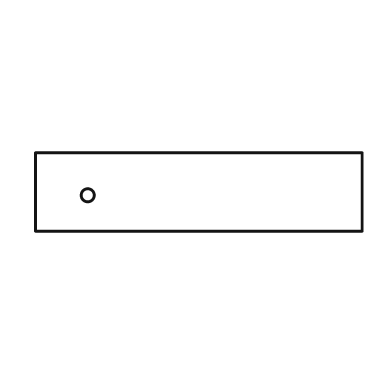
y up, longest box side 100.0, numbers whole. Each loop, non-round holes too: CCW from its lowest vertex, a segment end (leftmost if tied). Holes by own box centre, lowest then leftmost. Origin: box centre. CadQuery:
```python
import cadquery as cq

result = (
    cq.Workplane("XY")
    .moveTo(-50.0, -12.0)
    .lineTo(50.0, -12.0)
    .lineTo(50.0, 12.0)
    .lineTo(-50.0, 12.0)
    .close()
    .moveTo(-34.0, -1.0)
    .circle(2.0)
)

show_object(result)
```